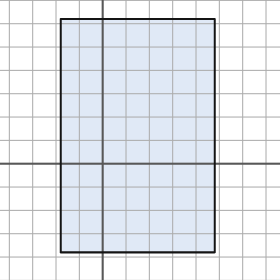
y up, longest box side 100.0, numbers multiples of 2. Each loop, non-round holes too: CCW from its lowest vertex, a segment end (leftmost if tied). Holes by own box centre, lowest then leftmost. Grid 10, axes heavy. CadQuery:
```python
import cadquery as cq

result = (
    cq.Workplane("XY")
    .moveTo(-18.0, -38.0)
    .lineTo(48.0, -38.0)
    .lineTo(48.0, 62.0)
    .lineTo(-18.0, 62.0)
    .close()
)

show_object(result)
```